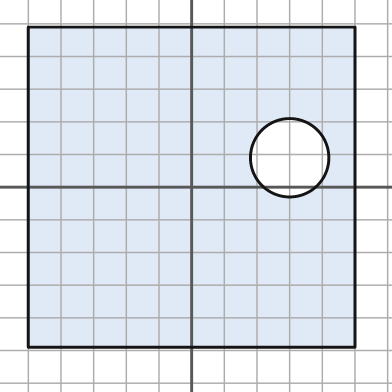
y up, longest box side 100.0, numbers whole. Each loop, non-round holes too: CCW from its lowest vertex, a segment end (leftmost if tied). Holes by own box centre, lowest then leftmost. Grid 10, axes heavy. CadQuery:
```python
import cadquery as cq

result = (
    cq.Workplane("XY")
    .moveTo(-50.0, -49.0)
    .lineTo(50.0, -49.0)
    .lineTo(50.0, 49.0)
    .lineTo(-50.0, 49.0)
    .close()
    .moveTo(30.0, 9.0)
    .circle(12.0)
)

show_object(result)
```